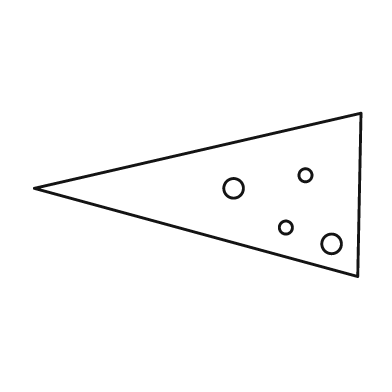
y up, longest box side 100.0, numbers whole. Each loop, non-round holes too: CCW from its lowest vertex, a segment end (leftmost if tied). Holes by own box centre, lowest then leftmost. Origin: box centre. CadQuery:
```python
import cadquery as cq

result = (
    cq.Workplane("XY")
    .moveTo(49.0, -25.0)
    .lineTo(50.0, 25.0)
    .lineTo(-50.0, 2.0)
    .close()
    .moveTo(41.0, -15.0)
    .circle(3.0)
    .moveTo(27.0, -10.0)
    .circle(2.0)
    .moveTo(11.0, 2.0)
    .circle(3.0)
    .moveTo(33.0, 6.0)
    .circle(2.0)
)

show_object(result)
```